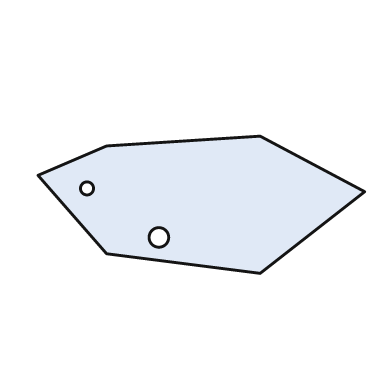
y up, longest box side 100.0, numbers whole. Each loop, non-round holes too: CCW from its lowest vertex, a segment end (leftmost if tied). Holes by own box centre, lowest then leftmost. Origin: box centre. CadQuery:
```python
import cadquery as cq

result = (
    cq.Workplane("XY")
    .moveTo(18.0, -21.0)
    .lineTo(50.0, 4.0)
    .lineTo(18.0, 21.0)
    .lineTo(-29.0, 18.0)
    .lineTo(-50.0, 9.0)
    .lineTo(-29.0, -15.0)
    .close()
    .moveTo(-13.0, -10.0)
    .circle(3.0)
    .moveTo(-35.0, 5.0)
    .circle(2.0)
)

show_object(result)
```